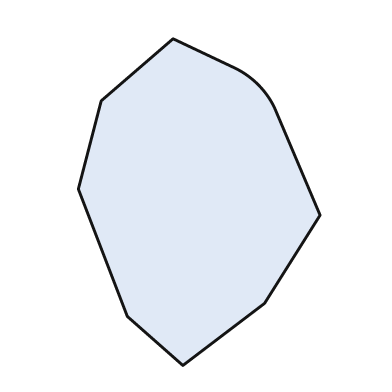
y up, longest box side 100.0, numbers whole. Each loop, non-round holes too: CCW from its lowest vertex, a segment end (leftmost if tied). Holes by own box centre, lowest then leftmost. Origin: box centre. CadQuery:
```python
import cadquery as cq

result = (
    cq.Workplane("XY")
    .moveTo(-5.0, -50.0)
    .lineTo(20.0, -31.0)
    .lineTo(37.0, -4.0)
    .lineTo(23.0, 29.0)
    .threePointArc((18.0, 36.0), (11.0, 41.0))
    .lineTo(-8.0, 50.0)
    .lineTo(-30.0, 31.0)
    .lineTo(-37.0, 4.0)
    .lineTo(-22.0, -35.0)
    .close()
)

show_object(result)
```